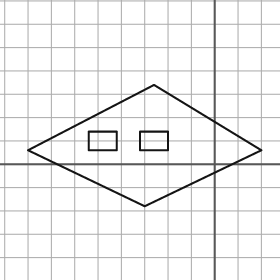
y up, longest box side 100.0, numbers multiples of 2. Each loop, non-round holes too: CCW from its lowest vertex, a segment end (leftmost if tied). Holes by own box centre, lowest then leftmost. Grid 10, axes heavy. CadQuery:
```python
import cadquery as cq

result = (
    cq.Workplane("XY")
    .moveTo(-30.0, -18.0)
    .lineTo(20.0, 6.0)
    .lineTo(-26.0, 34.0)
    .lineTo(-80.0, 6.0)
    .close()
    .moveTo(-54.0, 6.0)
    .lineTo(-42.0, 6.0)
    .lineTo(-42.0, 14.0)
    .lineTo(-54.0, 14.0)
    .close()
    .moveTo(-32.0, 6.0)
    .lineTo(-20.0, 6.0)
    .lineTo(-20.0, 14.0)
    .lineTo(-32.0, 14.0)
    .close()
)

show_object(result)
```